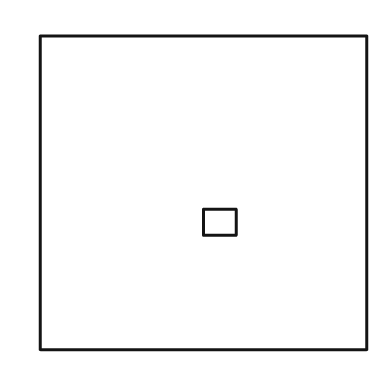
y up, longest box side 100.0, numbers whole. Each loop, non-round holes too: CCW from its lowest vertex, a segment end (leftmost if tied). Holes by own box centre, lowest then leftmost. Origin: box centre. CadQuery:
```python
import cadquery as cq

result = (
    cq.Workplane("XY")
    .moveTo(-50.0, -48.0)
    .lineTo(50.0, -48.0)
    .lineTo(50.0, 48.0)
    .lineTo(-50.0, 48.0)
    .close()
    .moveTo(0.0, -13.0)
    .lineTo(10.0, -13.0)
    .lineTo(10.0, -5.0)
    .lineTo(0.0, -5.0)
    .close()
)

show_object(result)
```